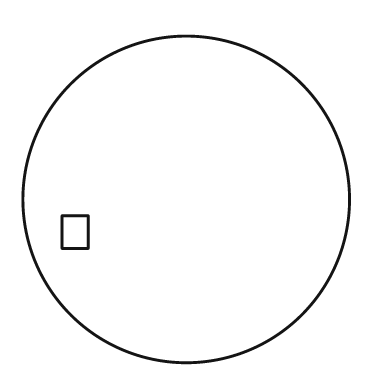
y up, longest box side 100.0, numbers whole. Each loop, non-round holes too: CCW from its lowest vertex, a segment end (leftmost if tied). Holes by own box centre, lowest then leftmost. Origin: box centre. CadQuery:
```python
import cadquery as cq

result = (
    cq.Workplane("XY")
    .moveTo(0.0, 0.0)
    .circle(50.0)
    .moveTo(-38.0, -15.0)
    .lineTo(-30.0, -15.0)
    .lineTo(-30.0, -5.0)
    .lineTo(-38.0, -5.0)
    .close()
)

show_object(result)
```